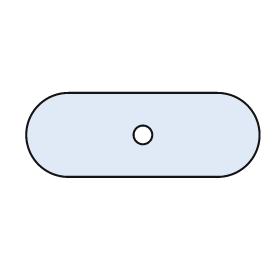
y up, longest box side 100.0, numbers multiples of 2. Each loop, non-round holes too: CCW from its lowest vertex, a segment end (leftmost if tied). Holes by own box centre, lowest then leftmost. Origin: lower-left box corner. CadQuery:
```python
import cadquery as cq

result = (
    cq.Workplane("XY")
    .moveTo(18.0, 0.0)
    .lineTo(82.0, 0.0)
    .threePointArc((100.0, 18.0), (82.0, 36.0))
    .lineTo(18.0, 36.0)
    .threePointArc((0.0, 18.0), (18.0, 0.0))
    .close()
    .moveTo(50.0, 18.0)
    .circle(4.0)
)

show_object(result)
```